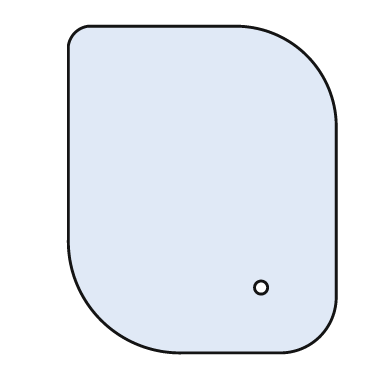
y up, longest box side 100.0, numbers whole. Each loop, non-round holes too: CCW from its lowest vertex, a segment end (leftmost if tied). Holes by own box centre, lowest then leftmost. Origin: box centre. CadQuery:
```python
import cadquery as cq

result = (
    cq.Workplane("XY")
    .moveTo(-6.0, -50.0)
    .lineTo(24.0, -50.0)
    .threePointArc((36.0, -45.0), (41.0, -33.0))
    .lineTo(41.0, 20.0)
    .threePointArc((32.0, 41.0), (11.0, 50.0))
    .lineTo(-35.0, 50.0)
    .threePointArc((-39.0, 48.0), (-41.0, 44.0))
    .lineTo(-41.0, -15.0)
    .threePointArc((-31.0, -40.0), (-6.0, -50.0))
    .close()
    .moveTo(18.0, -30.0)
    .circle(2.0)
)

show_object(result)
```